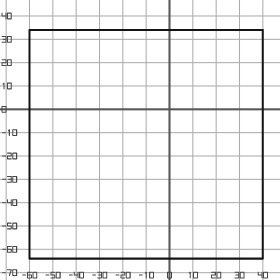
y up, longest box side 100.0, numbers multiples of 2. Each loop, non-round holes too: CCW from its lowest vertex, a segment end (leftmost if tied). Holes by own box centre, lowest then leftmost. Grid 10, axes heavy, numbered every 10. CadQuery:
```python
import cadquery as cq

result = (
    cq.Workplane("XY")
    .moveTo(-60.0, -64.0)
    .lineTo(40.0, -64.0)
    .lineTo(40.0, 34.0)
    .lineTo(-60.0, 34.0)
    .close()
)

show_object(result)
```